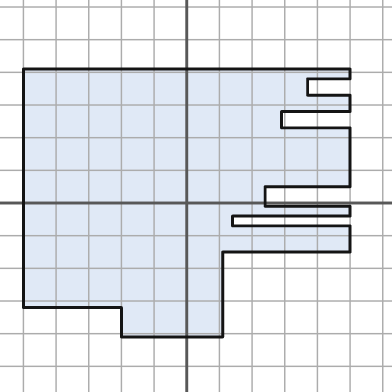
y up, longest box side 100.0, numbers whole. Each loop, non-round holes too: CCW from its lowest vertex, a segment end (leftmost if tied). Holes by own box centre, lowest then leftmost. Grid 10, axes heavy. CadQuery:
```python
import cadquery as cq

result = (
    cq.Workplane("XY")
    .moveTo(-20.0, -41.0)
    .lineTo(11.0, -41.0)
    .lineTo(11.0, -15.0)
    .lineTo(50.0, -15.0)
    .lineTo(50.0, -7.0)
    .lineTo(14.0, -7.0)
    .lineTo(14.0, -4.0)
    .lineTo(50.0, -4.0)
    .lineTo(50.0, -1.0)
    .lineTo(24.0, -1.0)
    .lineTo(24.0, 5.0)
    .lineTo(50.0, 5.0)
    .lineTo(50.0, 23.0)
    .lineTo(29.0, 23.0)
    .lineTo(29.0, 28.0)
    .lineTo(50.0, 28.0)
    .lineTo(50.0, 33.0)
    .lineTo(37.0, 33.0)
    .lineTo(37.0, 38.0)
    .lineTo(50.0, 38.0)
    .lineTo(50.0, 41.0)
    .lineTo(-50.0, 41.0)
    .lineTo(-50.0, -32.0)
    .lineTo(-20.0, -32.0)
    .close()
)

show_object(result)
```